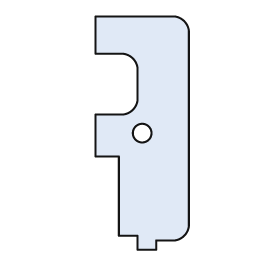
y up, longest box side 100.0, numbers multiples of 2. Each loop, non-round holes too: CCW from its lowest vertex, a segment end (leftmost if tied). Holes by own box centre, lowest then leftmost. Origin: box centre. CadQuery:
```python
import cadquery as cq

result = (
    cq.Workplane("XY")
    .moveTo(-2.0, -50.0)
    .lineTo(6.0, -50.0)
    .lineTo(6.0, -46.0)
    .lineTo(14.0, -46.0)
    .threePointArc((18.0, -44.0), (20.0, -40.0))
    .lineTo(20.0, 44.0)
    .threePointArc((18.0, 48.0), (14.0, 50.0))
    .lineTo(-20.0, 50.0)
    .lineTo(-20.0, 34.0)
    .lineTo(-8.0, 34.0)
    .threePointArc((-4.0, 32.0), (-2.0, 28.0))
    .lineTo(-2.0, 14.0)
    .threePointArc((-4.0, 10.0), (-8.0, 8.0))
    .lineTo(-20.0, 8.0)
    .lineTo(-20.0, -10.0)
    .lineTo(-10.0, -10.0)
    .lineTo(-10.0, -44.0)
    .lineTo(-2.0, -44.0)
    .close()
    .moveTo(0.0, 0.0)
    .circle(4.0)
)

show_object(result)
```